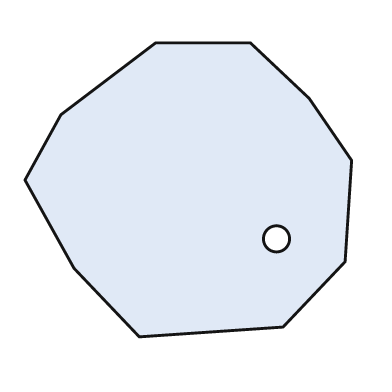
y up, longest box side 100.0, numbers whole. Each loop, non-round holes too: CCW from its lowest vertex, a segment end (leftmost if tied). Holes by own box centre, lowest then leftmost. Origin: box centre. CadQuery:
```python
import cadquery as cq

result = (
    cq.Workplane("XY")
    .moveTo(-15.0, -45.0)
    .lineTo(29.0, -42.0)
    .lineTo(48.0, -22.0)
    .lineTo(50.0, 9.0)
    .lineTo(37.0, 28.0)
    .lineTo(19.0, 45.0)
    .lineTo(-10.0, 45.0)
    .lineTo(-39.0, 23.0)
    .lineTo(-50.0, 3.0)
    .lineTo(-35.0, -24.0)
    .close()
    .moveTo(27.0, -15.0)
    .circle(4.0)
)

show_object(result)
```